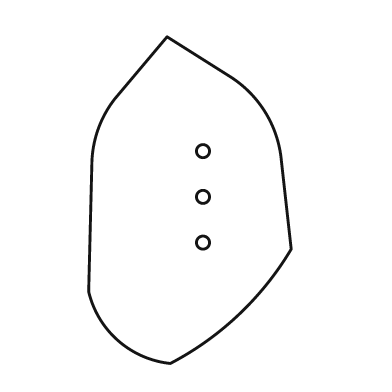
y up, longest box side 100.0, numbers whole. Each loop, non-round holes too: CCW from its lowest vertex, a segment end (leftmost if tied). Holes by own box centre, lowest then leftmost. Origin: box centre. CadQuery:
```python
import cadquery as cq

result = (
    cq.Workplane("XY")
    .moveTo(-6.0, -50.0)
    .threePointArc((15.0, -35.0), (31.0, -15.0))
    .lineTo(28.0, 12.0)
    .threePointArc((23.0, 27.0), (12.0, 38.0))
    .lineTo(-7.0, 50.0)
    .lineTo(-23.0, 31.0)
    .threePointArc((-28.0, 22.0), (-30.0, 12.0))
    .lineTo(-31.0, -28.0)
    .threePointArc((-22.0, -43.0), (-6.0, -50.0))
    .close()
    .moveTo(4.0, -13.0)
    .circle(2.0)
    .moveTo(4.0, 1.0)
    .circle(2.0)
    .moveTo(4.0, 15.0)
    .circle(2.0)
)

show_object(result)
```